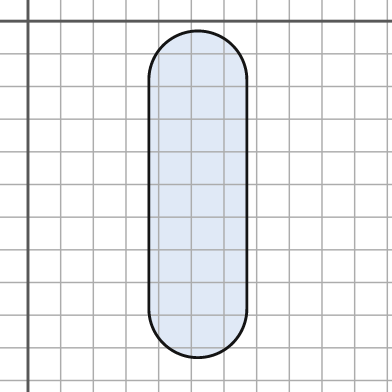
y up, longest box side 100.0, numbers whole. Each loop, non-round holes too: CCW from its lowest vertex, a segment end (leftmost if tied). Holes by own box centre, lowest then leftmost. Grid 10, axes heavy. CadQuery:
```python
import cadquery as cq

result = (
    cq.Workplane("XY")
    .moveTo(37.0, -88.0)
    .threePointArc((52.0, -103.0), (67.0, -88.0))
    .lineTo(67.0, -18.0)
    .threePointArc((52.0, -3.0), (37.0, -18.0))
    .close()
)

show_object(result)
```